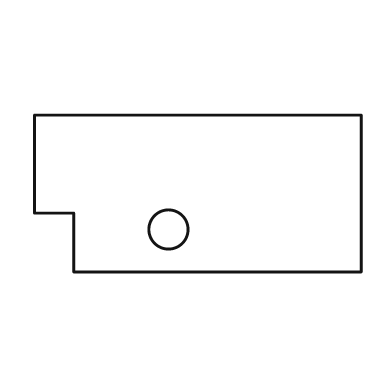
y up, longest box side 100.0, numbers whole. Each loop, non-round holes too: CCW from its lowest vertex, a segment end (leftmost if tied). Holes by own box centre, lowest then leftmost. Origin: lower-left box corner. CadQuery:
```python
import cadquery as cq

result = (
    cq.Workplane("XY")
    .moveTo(12.0, 0.0)
    .lineTo(100.0, 0.0)
    .lineTo(100.0, 48.0)
    .lineTo(0.0, 48.0)
    .lineTo(0.0, 18.0)
    .lineTo(12.0, 18.0)
    .close()
    .moveTo(41.0, 13.0)
    .circle(6.0)
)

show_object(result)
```